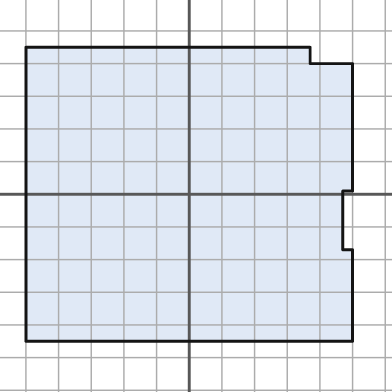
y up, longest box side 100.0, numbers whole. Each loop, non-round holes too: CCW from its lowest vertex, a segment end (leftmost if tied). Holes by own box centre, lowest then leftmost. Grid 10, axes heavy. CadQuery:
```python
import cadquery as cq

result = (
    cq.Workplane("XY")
    .moveTo(-50.0, -45.0)
    .lineTo(50.0, -45.0)
    .lineTo(50.0, -17.0)
    .lineTo(47.0, -17.0)
    .lineTo(47.0, 1.0)
    .lineTo(50.0, 1.0)
    .lineTo(50.0, 40.0)
    .lineTo(37.0, 40.0)
    .lineTo(37.0, 45.0)
    .lineTo(-50.0, 45.0)
    .close()
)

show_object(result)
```